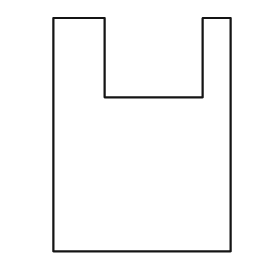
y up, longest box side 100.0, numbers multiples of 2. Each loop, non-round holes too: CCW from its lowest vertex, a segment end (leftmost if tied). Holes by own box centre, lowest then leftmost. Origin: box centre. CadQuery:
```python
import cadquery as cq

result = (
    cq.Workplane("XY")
    .moveTo(-38.0, -50.0)
    .lineTo(38.0, -50.0)
    .lineTo(38.0, 50.0)
    .lineTo(26.0, 50.0)
    .lineTo(26.0, 16.0)
    .lineTo(-16.0, 16.0)
    .lineTo(-16.0, 50.0)
    .lineTo(-38.0, 50.0)
    .close()
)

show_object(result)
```